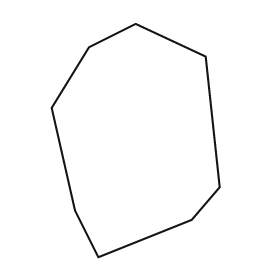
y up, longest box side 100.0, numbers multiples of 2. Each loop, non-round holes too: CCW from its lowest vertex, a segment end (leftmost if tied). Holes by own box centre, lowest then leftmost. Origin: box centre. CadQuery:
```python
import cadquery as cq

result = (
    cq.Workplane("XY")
    .moveTo(-16.0, -50.0)
    .lineTo(24.0, -34.0)
    .lineTo(36.0, -20.0)
    .lineTo(30.0, 36.0)
    .lineTo(0.0, 50.0)
    .lineTo(-20.0, 40.0)
    .lineTo(-36.0, 14.0)
    .lineTo(-26.0, -30.0)
    .close()
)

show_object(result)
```